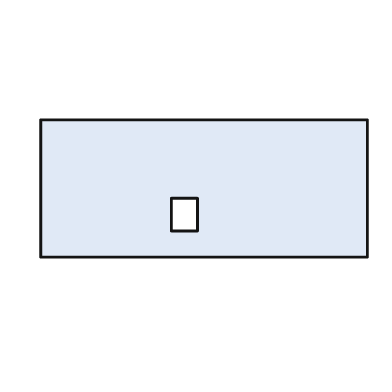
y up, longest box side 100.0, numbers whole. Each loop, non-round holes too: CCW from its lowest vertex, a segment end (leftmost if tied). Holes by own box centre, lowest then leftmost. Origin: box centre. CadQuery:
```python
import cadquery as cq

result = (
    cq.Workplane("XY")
    .moveTo(-50.0, -21.0)
    .lineTo(50.0, -21.0)
    .lineTo(50.0, 21.0)
    .lineTo(-50.0, 21.0)
    .close()
    .moveTo(-10.0, -13.0)
    .lineTo(-2.0, -13.0)
    .lineTo(-2.0, -3.0)
    .lineTo(-10.0, -3.0)
    .close()
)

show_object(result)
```